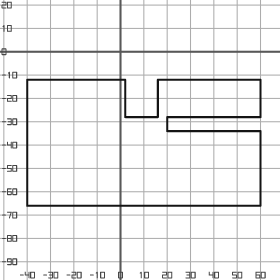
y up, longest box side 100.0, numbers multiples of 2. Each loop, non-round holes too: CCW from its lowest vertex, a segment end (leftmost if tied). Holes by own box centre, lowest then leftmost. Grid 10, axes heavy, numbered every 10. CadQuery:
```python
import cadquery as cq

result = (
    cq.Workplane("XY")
    .moveTo(-40.0, -66.0)
    .lineTo(60.0, -66.0)
    .lineTo(60.0, -34.0)
    .lineTo(20.0, -34.0)
    .lineTo(20.0, -28.0)
    .lineTo(60.0, -28.0)
    .lineTo(60.0, -12.0)
    .lineTo(16.0, -12.0)
    .lineTo(16.0, -28.0)
    .lineTo(2.0, -28.0)
    .lineTo(2.0, -12.0)
    .lineTo(-40.0, -12.0)
    .close()
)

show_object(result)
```